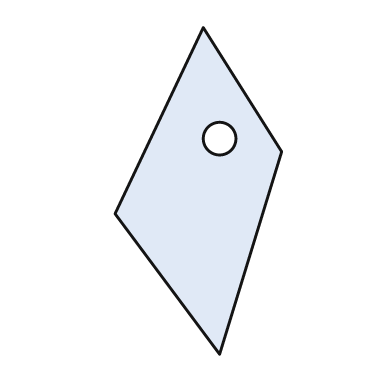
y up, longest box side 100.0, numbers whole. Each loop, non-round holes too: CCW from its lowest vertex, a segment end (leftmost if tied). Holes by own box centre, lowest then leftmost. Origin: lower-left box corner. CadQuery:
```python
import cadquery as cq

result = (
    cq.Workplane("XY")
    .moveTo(32.0, 0.0)
    .lineTo(51.0, 62.0)
    .lineTo(27.0, 100.0)
    .lineTo(0.0, 43.0)
    .close()
    .moveTo(32.0, 66.0)
    .circle(5.0)
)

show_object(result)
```